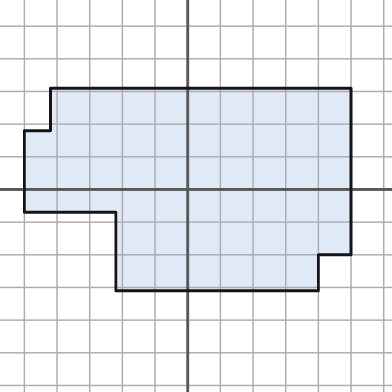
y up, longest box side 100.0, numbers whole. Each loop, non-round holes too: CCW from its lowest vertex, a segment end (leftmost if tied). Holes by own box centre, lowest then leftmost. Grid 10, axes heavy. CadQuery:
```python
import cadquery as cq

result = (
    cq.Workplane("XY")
    .moveTo(-22.0, -31.0)
    .lineTo(40.0, -31.0)
    .lineTo(40.0, -20.0)
    .lineTo(50.0, -20.0)
    .lineTo(50.0, 31.0)
    .lineTo(-42.0, 31.0)
    .lineTo(-42.0, 18.0)
    .lineTo(-50.0, 18.0)
    .lineTo(-50.0, -7.0)
    .lineTo(-22.0, -7.0)
    .close()
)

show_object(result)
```